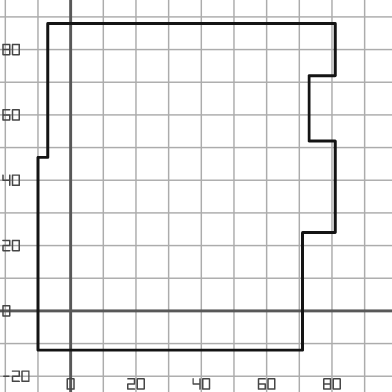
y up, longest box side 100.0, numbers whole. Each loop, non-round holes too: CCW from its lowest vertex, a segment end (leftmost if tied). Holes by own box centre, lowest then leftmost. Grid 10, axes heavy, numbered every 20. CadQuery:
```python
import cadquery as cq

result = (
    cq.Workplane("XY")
    .moveTo(-10.0, -12.0)
    .lineTo(71.0, -12.0)
    .lineTo(71.0, 24.0)
    .lineTo(81.0, 24.0)
    .lineTo(81.0, 52.0)
    .lineTo(73.0, 52.0)
    .lineTo(73.0, 72.0)
    .lineTo(81.0, 72.0)
    .lineTo(81.0, 88.0)
    .lineTo(-7.0, 88.0)
    .lineTo(-7.0, 47.0)
    .lineTo(-10.0, 47.0)
    .close()
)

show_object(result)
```